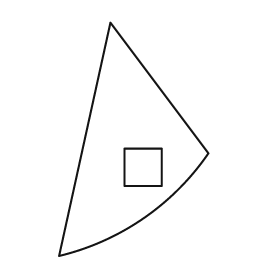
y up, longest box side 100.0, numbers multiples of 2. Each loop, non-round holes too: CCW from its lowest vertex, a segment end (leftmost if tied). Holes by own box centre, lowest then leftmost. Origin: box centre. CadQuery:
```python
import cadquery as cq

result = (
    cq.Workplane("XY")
    .moveTo(-32.0, -50.0)
    .threePointArc((4.0, -34.0), (32.0, -6.0))
    .lineTo(-10.0, 50.0)
    .close()
    .moveTo(-4.0, -20.0)
    .lineTo(12.0, -20.0)
    .lineTo(12.0, -4.0)
    .lineTo(-4.0, -4.0)
    .close()
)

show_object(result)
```